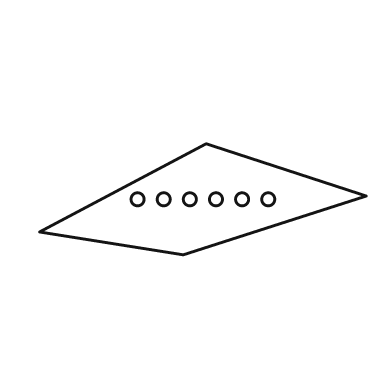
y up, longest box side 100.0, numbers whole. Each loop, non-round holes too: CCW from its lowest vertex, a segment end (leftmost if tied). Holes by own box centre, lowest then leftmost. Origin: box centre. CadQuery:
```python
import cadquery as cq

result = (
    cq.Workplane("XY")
    .moveTo(-6.0, -17.0)
    .lineTo(50.0, 1.0)
    .lineTo(1.0, 17.0)
    .lineTo(-50.0, -10.0)
    .close()
    .moveTo(-20.0, 0.0)
    .circle(2.0)
    .moveTo(-12.0, 0.0)
    .circle(2.0)
    .moveTo(-4.0, 0.0)
    .circle(2.0)
    .moveTo(4.0, 0.0)
    .circle(2.0)
    .moveTo(12.0, 0.0)
    .circle(2.0)
    .moveTo(20.0, 0.0)
    .circle(2.0)
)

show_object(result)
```